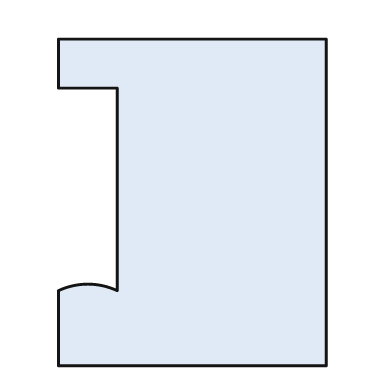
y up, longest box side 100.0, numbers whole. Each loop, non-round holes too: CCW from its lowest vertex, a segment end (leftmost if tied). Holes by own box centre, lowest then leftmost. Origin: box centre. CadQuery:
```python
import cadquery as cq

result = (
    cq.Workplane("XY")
    .moveTo(-41.0, -50.0)
    .lineTo(41.0, -50.0)
    .lineTo(41.0, 50.0)
    .lineTo(-41.0, 50.0)
    .lineTo(-41.0, 35.0)
    .lineTo(-23.0, 35.0)
    .lineTo(-23.0, -27.0)
    .threePointArc((-32.0, -25.0), (-41.0, -27.0))
    .close()
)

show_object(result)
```